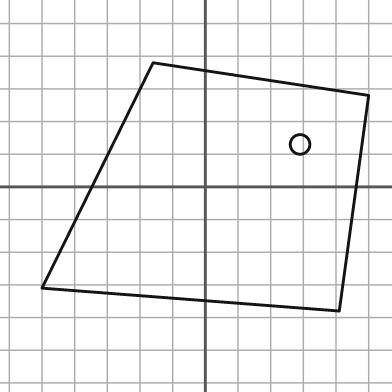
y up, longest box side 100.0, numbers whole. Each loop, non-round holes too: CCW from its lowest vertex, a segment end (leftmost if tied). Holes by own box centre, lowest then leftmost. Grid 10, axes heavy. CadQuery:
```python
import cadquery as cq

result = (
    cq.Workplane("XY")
    .moveTo(41.0, -38.0)
    .lineTo(50.0, 28.0)
    .lineTo(-16.0, 38.0)
    .lineTo(-50.0, -31.0)
    .close()
    .moveTo(29.0, 13.0)
    .circle(3.0)
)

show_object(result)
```